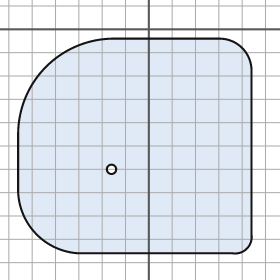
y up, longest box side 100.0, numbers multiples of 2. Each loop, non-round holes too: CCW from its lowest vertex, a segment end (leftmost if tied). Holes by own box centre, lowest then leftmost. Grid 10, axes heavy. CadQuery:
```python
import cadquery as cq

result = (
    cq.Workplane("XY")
    .moveTo(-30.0, -96.0)
    .lineTo(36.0, -96.0)
    .threePointArc((42.0, -94.0), (44.0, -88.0))
    .lineTo(44.0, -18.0)
    .threePointArc((40.0, -8.0), (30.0, -4.0))
    .lineTo(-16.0, -4.0)
    .threePointArc((-44.0, -16.0), (-56.0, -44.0))
    .lineTo(-56.0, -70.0)
    .threePointArc((-48.0, -88.0), (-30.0, -96.0))
    .close()
    .moveTo(-16.0, -60.0)
    .circle(2.0)
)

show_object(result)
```